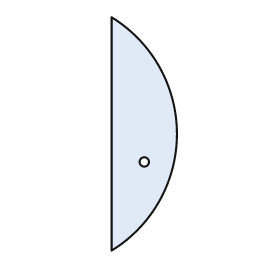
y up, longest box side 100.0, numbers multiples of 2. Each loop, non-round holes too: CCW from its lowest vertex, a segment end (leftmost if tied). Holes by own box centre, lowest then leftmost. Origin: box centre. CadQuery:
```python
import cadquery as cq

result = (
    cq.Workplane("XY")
    .moveTo(-14.0, -50.0)
    .threePointArc((14.0, 0.0), (-14.0, 50.0))
    .close()
    .moveTo(0.0, -12.0)
    .circle(2.0)
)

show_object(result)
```